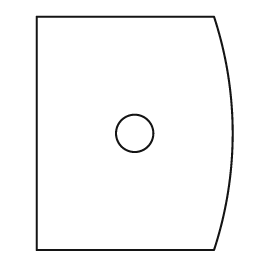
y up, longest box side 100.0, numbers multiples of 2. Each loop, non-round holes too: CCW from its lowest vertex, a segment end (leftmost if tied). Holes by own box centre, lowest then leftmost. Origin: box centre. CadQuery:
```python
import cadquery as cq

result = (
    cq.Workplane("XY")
    .moveTo(-42.0, -50.0)
    .lineTo(34.0, -50.0)
    .threePointArc((42.0, 0.0), (34.0, 50.0))
    .lineTo(-42.0, 50.0)
    .close()
    .moveTo(0.0, 0.0)
    .circle(8.0)
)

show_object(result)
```